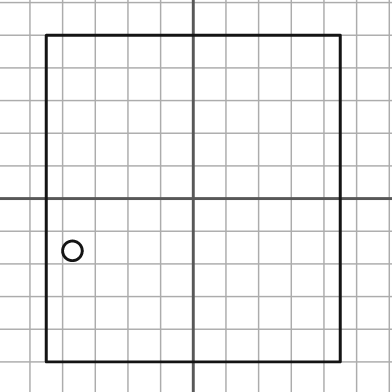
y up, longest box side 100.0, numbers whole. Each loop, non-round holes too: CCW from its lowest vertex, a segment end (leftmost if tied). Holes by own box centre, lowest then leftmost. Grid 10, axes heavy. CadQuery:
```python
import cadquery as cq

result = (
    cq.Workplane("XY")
    .moveTo(-45.0, -50.0)
    .lineTo(45.0, -50.0)
    .lineTo(45.0, 50.0)
    .lineTo(-45.0, 50.0)
    .close()
    .moveTo(-37.0, -16.0)
    .circle(3.0)
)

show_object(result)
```